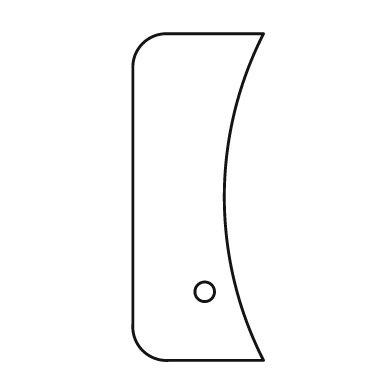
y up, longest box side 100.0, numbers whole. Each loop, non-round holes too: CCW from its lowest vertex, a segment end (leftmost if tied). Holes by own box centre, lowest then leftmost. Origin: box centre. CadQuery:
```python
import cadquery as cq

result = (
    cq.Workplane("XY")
    .moveTo(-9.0, -50.0)
    .lineTo(20.0, -50.0)
    .threePointArc((8.0, 0.0), (20.0, 50.0))
    .lineTo(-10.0, 50.0)
    .threePointArc((-17.0, 47.0), (-20.0, 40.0))
    .lineTo(-20.0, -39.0)
    .threePointArc((-17.0, -47.0), (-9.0, -50.0))
    .close()
    .moveTo(2.0, -29.0)
    .circle(3.0)
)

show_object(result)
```